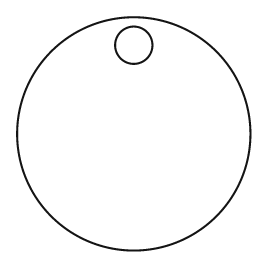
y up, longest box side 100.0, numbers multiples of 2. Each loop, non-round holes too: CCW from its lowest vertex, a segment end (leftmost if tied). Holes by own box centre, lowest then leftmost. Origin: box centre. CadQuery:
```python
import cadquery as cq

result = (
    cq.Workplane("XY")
    .moveTo(0.0, 0.0)
    .circle(50.0)
    .moveTo(0.0, 38.0)
    .circle(8.0)
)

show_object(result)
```